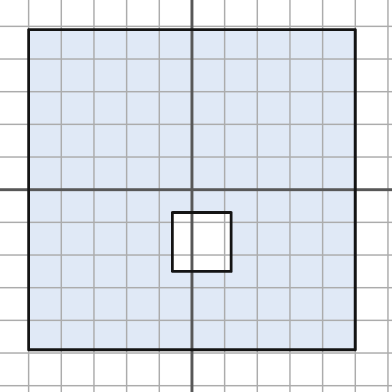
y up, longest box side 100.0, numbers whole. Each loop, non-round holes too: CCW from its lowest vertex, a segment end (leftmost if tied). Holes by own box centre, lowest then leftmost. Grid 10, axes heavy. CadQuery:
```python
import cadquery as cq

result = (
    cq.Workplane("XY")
    .moveTo(-50.0, -49.0)
    .lineTo(50.0, -49.0)
    .lineTo(50.0, 49.0)
    .lineTo(-50.0, 49.0)
    .close()
    .moveTo(-6.0, -25.0)
    .lineTo(12.0, -25.0)
    .lineTo(12.0, -7.0)
    .lineTo(-6.0, -7.0)
    .close()
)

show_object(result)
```